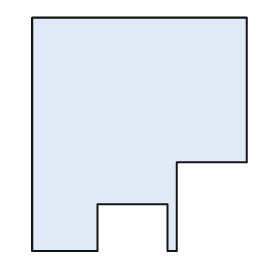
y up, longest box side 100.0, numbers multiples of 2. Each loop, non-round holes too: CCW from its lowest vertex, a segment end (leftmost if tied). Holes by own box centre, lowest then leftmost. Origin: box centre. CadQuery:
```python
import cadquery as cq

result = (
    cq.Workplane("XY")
    .moveTo(-46.0, -50.0)
    .lineTo(-18.0, -50.0)
    .lineTo(-18.0, -30.0)
    .lineTo(12.0, -30.0)
    .lineTo(12.0, -50.0)
    .lineTo(16.0, -50.0)
    .lineTo(16.0, -12.0)
    .lineTo(46.0, -12.0)
    .lineTo(46.0, 50.0)
    .lineTo(-46.0, 50.0)
    .close()
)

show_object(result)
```